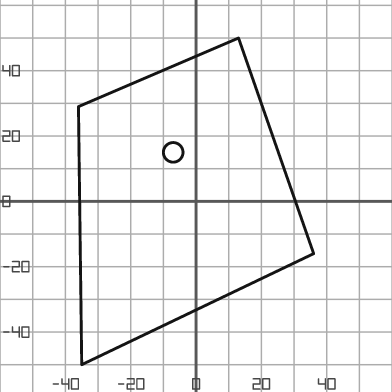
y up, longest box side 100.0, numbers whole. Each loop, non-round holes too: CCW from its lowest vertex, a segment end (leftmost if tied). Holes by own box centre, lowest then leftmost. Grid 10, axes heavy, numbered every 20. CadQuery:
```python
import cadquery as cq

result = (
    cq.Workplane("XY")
    .moveTo(-35.0, -50.0)
    .lineTo(36.0, -16.0)
    .lineTo(13.0, 50.0)
    .lineTo(-36.0, 29.0)
    .close()
    .moveTo(-7.0, 15.0)
    .circle(3.0)
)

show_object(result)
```